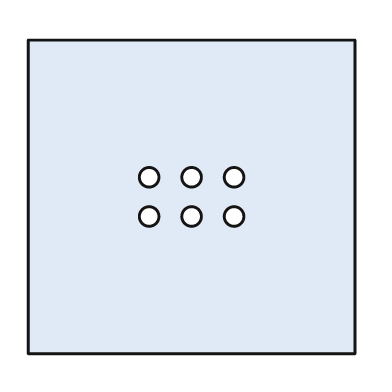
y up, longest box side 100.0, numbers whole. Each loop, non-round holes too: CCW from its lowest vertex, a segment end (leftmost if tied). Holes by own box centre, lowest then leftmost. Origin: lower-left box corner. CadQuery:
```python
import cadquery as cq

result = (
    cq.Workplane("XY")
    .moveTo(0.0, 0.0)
    .lineTo(100.0, 0.0)
    .lineTo(100.0, 96.0)
    .lineTo(0.0, 96.0)
    .close()
    .moveTo(37.0, 42.0)
    .circle(3.0)
    .moveTo(50.0, 42.0)
    .circle(3.0)
    .moveTo(63.0, 42.0)
    .circle(3.0)
    .moveTo(37.0, 54.0)
    .circle(3.0)
    .moveTo(50.0, 54.0)
    .circle(3.0)
    .moveTo(63.0, 54.0)
    .circle(3.0)
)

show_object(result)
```